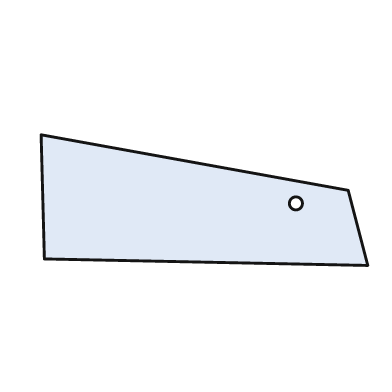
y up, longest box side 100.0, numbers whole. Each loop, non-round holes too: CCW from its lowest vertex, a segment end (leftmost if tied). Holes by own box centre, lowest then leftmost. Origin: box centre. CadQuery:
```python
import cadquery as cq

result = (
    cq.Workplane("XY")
    .moveTo(50.0, -20.0)
    .lineTo(44.0, 3.0)
    .lineTo(-50.0, 20.0)
    .lineTo(-49.0, -18.0)
    .close()
    .moveTo(28.0, -1.0)
    .circle(2.0)
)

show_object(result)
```